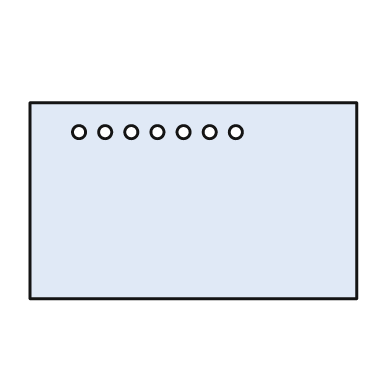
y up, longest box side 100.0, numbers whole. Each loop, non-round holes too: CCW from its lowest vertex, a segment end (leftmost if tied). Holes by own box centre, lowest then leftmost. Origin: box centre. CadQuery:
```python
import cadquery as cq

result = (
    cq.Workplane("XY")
    .moveTo(-50.0, -30.0)
    .lineTo(50.0, -30.0)
    .lineTo(50.0, 30.0)
    .lineTo(-50.0, 30.0)
    .close()
    .moveTo(-35.0, 21.0)
    .circle(2.0)
    .moveTo(-27.0, 21.0)
    .circle(2.0)
    .moveTo(-19.0, 21.0)
    .circle(2.0)
    .moveTo(-11.0, 21.0)
    .circle(2.0)
    .moveTo(-3.0, 21.0)
    .circle(2.0)
    .moveTo(5.0, 21.0)
    .circle(2.0)
    .moveTo(13.0, 21.0)
    .circle(2.0)
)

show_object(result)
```